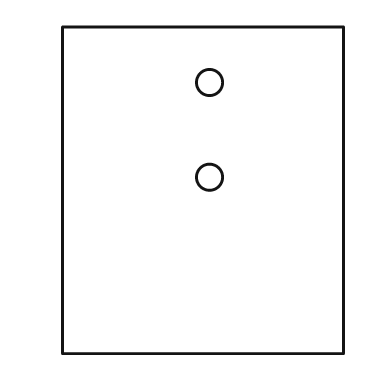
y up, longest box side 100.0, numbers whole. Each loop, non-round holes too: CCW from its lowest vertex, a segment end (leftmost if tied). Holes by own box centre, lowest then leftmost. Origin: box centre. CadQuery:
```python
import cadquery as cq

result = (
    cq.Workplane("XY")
    .moveTo(-43.0, -50.0)
    .lineTo(43.0, -50.0)
    .lineTo(43.0, 50.0)
    .lineTo(-43.0, 50.0)
    .close()
    .moveTo(2.0, 4.0)
    .circle(4.0)
    .moveTo(2.0, 33.0)
    .circle(4.0)
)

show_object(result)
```